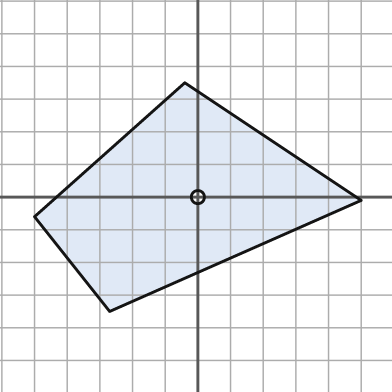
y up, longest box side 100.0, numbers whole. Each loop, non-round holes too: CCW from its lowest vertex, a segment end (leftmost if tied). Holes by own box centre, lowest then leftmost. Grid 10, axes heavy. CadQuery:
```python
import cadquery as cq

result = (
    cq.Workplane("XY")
    .moveTo(-27.0, -35.0)
    .lineTo(50.0, -1.0)
    .lineTo(-4.0, 35.0)
    .lineTo(-50.0, -6.0)
    .close()
    .moveTo(0.0, 0.0)
    .circle(2.0)
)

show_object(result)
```